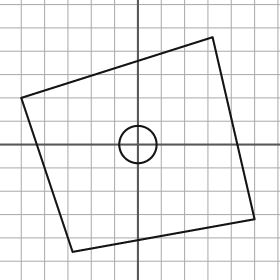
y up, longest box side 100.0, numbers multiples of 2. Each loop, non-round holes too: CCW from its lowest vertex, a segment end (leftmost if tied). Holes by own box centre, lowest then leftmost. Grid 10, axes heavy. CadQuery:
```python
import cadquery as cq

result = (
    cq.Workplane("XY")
    .moveTo(-28.0, -46.0)
    .lineTo(50.0, -32.0)
    .lineTo(32.0, 46.0)
    .lineTo(-50.0, 20.0)
    .close()
    .moveTo(0.0, 0.0)
    .circle(8.0)
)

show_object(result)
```